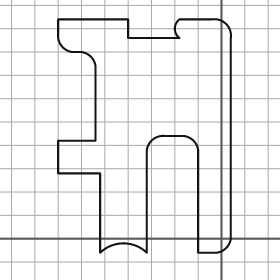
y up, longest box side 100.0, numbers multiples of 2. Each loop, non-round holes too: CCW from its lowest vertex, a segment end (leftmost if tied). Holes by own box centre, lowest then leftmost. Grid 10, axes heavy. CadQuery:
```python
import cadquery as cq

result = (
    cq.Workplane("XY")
    .moveTo(-52.0, -6.0)
    .threePointArc((-42.0, -2.0), (-32.0, -6.0))
    .lineTo(-32.0, 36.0)
    .threePointArc((-30.0, 42.0), (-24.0, 44.0))
    .lineTo(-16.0, 44.0)
    .threePointArc((-12.0, 42.0), (-10.0, 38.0))
    .lineTo(-10.0, -6.0)
    .lineTo(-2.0, -6.0)
    .threePointArc((2.0, -4.0), (4.0, 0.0))
    .lineTo(4.0, 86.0)
    .threePointArc((2.0, 92.0), (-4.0, 94.0))
    .lineTo(-18.0, 94.0)
    .threePointArc((-20.0, 90.0), (-18.0, 86.0))
    .lineTo(-40.0, 86.0)
    .lineTo(-40.0, 94.0)
    .lineTo(-70.0, 94.0)
    .lineTo(-70.0, 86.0)
    .threePointArc((-68.0, 82.0), (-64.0, 80.0))
    .lineTo(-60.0, 80.0)
    .threePointArc((-56.0, 78.0), (-54.0, 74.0))
    .lineTo(-54.0, 42.0)
    .lineTo(-70.0, 42.0)
    .lineTo(-70.0, 28.0)
    .lineTo(-52.0, 28.0)
    .close()
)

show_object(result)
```